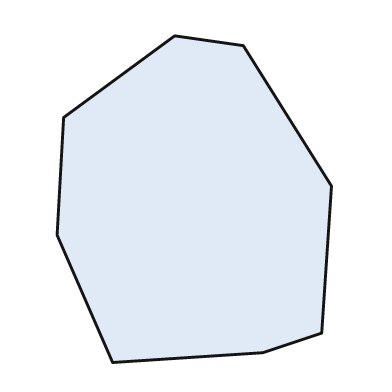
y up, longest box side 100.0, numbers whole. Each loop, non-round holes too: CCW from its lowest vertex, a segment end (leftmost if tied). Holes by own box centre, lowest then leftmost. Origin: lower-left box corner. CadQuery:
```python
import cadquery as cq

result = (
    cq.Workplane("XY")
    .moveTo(17.0, 0.0)
    .lineTo(63.0, 3.0)
    .lineTo(81.0, 9.0)
    .lineTo(84.0, 54.0)
    .lineTo(57.0, 97.0)
    .lineTo(36.0, 100.0)
    .lineTo(2.0, 75.0)
    .lineTo(0.0, 39.0)
    .close()
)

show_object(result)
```